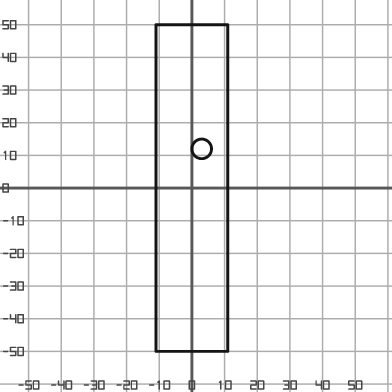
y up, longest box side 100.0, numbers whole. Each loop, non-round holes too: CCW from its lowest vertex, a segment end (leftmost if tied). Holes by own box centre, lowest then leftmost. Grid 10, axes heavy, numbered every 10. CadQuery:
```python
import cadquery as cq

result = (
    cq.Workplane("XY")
    .moveTo(-11.0, -50.0)
    .lineTo(11.0, -50.0)
    .lineTo(11.0, 50.0)
    .lineTo(-11.0, 50.0)
    .close()
    .moveTo(3.0, 12.0)
    .circle(3.0)
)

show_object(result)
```